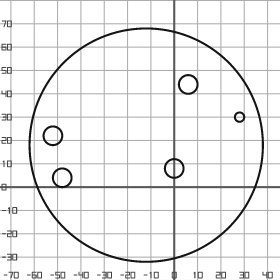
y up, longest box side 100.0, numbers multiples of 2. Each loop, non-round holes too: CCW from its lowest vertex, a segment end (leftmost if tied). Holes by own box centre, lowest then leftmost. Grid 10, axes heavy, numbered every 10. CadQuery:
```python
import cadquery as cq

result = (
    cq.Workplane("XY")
    .moveTo(-12.0, 18.0)
    .circle(50.0)
    .moveTo(-48.0, 4.0)
    .circle(4.0)
    .moveTo(0.0, 8.0)
    .circle(4.0)
    .moveTo(-52.0, 22.0)
    .circle(4.0)
    .moveTo(28.0, 30.0)
    .circle(2.0)
    .moveTo(6.0, 44.0)
    .circle(4.0)
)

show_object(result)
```